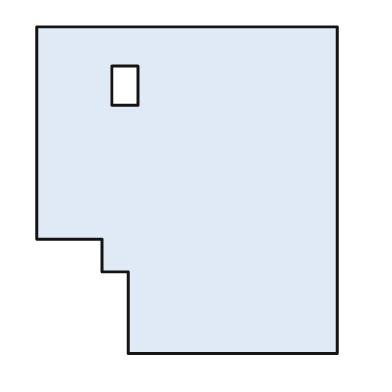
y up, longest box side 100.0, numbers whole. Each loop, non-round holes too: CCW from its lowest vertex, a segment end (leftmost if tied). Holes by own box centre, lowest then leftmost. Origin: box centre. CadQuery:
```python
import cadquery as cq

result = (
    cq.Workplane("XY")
    .moveTo(-18.0, -50.0)
    .lineTo(46.0, -50.0)
    .lineTo(46.0, 50.0)
    .lineTo(-46.0, 50.0)
    .lineTo(-46.0, -15.0)
    .lineTo(-26.0, -15.0)
    .lineTo(-26.0, -25.0)
    .lineTo(-18.0, -25.0)
    .close()
    .moveTo(-23.0, 26.0)
    .lineTo(-15.0, 26.0)
    .lineTo(-15.0, 38.0)
    .lineTo(-23.0, 38.0)
    .close()
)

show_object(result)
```